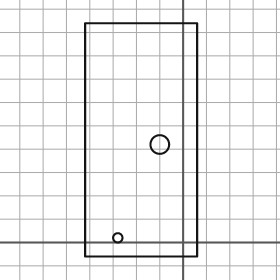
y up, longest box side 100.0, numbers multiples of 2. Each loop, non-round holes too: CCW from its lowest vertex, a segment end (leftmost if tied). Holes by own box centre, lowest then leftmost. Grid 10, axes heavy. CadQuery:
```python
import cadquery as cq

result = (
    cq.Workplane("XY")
    .moveTo(-42.0, -6.0)
    .lineTo(6.0, -6.0)
    .lineTo(6.0, 94.0)
    .lineTo(-42.0, 94.0)
    .close()
    .moveTo(-28.0, 2.0)
    .circle(2.0)
    .moveTo(-10.0, 42.0)
    .circle(4.0)
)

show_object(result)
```